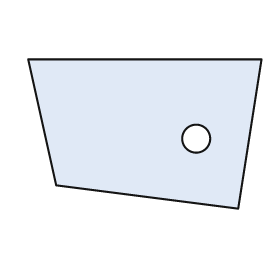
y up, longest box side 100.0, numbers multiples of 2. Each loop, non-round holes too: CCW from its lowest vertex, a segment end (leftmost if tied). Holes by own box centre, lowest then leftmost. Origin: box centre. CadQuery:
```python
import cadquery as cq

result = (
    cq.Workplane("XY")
    .moveTo(40.0, -32.0)
    .lineTo(50.0, 32.0)
    .lineTo(-50.0, 32.0)
    .lineTo(-38.0, -22.0)
    .close()
    .moveTo(22.0, -2.0)
    .circle(6.0)
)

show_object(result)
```